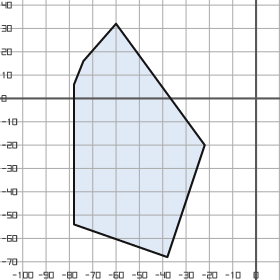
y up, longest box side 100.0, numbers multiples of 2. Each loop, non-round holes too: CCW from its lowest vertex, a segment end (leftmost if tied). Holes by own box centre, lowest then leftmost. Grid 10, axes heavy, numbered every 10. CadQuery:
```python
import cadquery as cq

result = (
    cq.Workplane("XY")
    .moveTo(-38.0, -68.0)
    .lineTo(-22.0, -20.0)
    .lineTo(-60.0, 32.0)
    .lineTo(-74.0, 16.0)
    .lineTo(-78.0, 6.0)
    .lineTo(-78.0, -54.0)
    .close()
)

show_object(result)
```